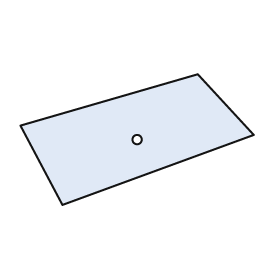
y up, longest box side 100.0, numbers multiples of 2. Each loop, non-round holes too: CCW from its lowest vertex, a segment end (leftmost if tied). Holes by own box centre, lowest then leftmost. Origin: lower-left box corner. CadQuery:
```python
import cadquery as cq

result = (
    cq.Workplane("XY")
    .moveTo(18.0, 0.0)
    .lineTo(100.0, 30.0)
    .lineTo(76.0, 56.0)
    .lineTo(0.0, 34.0)
    .close()
    .moveTo(50.0, 28.0)
    .circle(2.0)
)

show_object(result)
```